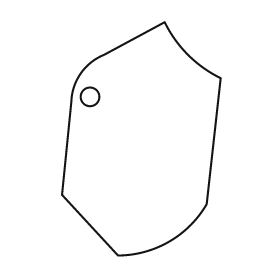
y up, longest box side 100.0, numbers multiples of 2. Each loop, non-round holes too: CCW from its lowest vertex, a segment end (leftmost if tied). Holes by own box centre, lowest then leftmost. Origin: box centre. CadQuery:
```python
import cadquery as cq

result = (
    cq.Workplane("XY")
    .moveTo(-10.0, -50.0)
    .threePointArc((12.0, -44.0), (28.0, -28.0))
    .lineTo(34.0, 26.0)
    .threePointArc((20.0, 36.0), (10.0, 50.0))
    .lineTo(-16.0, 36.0)
    .threePointArc((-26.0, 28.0), (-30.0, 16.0))
    .lineTo(-34.0, -24.0)
    .close()
    .moveTo(-22.0, 18.0)
    .circle(4.0)
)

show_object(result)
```